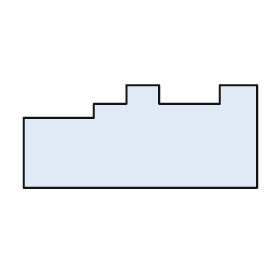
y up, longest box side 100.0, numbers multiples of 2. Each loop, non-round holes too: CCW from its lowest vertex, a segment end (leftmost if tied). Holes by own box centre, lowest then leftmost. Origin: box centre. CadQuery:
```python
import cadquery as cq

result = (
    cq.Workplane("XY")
    .moveTo(-50.0, -22.0)
    .lineTo(50.0, -22.0)
    .lineTo(50.0, 22.0)
    .lineTo(34.0, 22.0)
    .lineTo(34.0, 14.0)
    .lineTo(8.0, 14.0)
    .lineTo(8.0, 22.0)
    .lineTo(-6.0, 22.0)
    .lineTo(-6.0, 14.0)
    .lineTo(-20.0, 14.0)
    .lineTo(-20.0, 8.0)
    .lineTo(-50.0, 8.0)
    .close()
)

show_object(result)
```